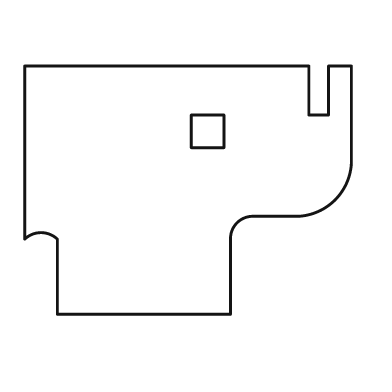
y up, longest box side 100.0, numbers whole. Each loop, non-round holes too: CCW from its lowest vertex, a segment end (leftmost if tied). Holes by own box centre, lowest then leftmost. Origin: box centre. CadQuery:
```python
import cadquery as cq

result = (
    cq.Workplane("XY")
    .moveTo(-40.0, -38.0)
    .lineTo(13.0, -38.0)
    .lineTo(13.0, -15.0)
    .threePointArc((15.0, -10.0), (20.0, -8.0))
    .lineTo(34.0, -8.0)
    .threePointArc((45.0, -3.0), (50.0, 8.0))
    .lineTo(50.0, 38.0)
    .lineTo(43.0, 38.0)
    .lineTo(43.0, 23.0)
    .lineTo(37.0, 23.0)
    .lineTo(37.0, 38.0)
    .lineTo(-50.0, 38.0)
    .lineTo(-50.0, -15.0)
    .threePointArc((-45.0, -13.0), (-40.0, -15.0))
    .close()
    .moveTo(1.0, 13.0)
    .lineTo(11.0, 13.0)
    .lineTo(11.0, 23.0)
    .lineTo(1.0, 23.0)
    .close()
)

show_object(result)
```